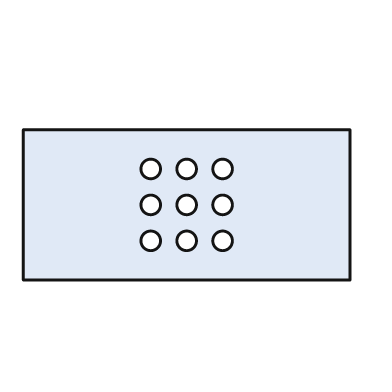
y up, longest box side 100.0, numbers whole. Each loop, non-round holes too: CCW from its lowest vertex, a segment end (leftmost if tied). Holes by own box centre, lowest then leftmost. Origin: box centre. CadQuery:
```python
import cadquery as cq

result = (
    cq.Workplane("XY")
    .moveTo(-50.0, -23.0)
    .lineTo(50.0, -23.0)
    .lineTo(50.0, 23.0)
    .lineTo(-50.0, 23.0)
    .close()
    .moveTo(-11.0, -11.0)
    .circle(3.0)
    .moveTo(0.0, -11.0)
    .circle(3.0)
    .moveTo(11.0, -11.0)
    .circle(3.0)
    .moveTo(-11.0, 0.0)
    .circle(3.0)
    .moveTo(0.0, 0.0)
    .circle(3.0)
    .moveTo(11.0, 0.0)
    .circle(3.0)
    .moveTo(-11.0, 11.0)
    .circle(3.0)
    .moveTo(0.0, 11.0)
    .circle(3.0)
    .moveTo(11.0, 11.0)
    .circle(3.0)
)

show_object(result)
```